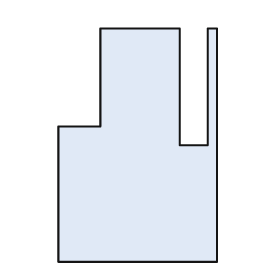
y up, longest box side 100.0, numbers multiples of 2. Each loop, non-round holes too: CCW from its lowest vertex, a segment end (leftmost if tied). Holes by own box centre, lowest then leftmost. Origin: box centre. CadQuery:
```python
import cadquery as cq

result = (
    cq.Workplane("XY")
    .moveTo(-34.0, -50.0)
    .lineTo(34.0, -50.0)
    .lineTo(34.0, 50.0)
    .lineTo(30.0, 50.0)
    .lineTo(30.0, 0.0)
    .lineTo(18.0, 0.0)
    .lineTo(18.0, 50.0)
    .lineTo(-16.0, 50.0)
    .lineTo(-16.0, 8.0)
    .lineTo(-34.0, 8.0)
    .close()
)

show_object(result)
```